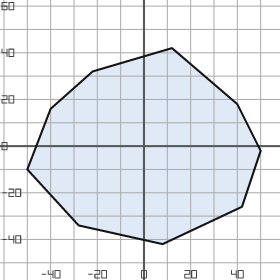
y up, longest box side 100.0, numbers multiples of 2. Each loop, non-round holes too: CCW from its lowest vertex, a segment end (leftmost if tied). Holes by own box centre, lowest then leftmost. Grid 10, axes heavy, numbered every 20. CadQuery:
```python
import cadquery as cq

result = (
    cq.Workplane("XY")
    .moveTo(8.0, -42.0)
    .lineTo(42.0, -26.0)
    .lineTo(50.0, -2.0)
    .lineTo(40.0, 18.0)
    .lineTo(12.0, 42.0)
    .lineTo(-22.0, 32.0)
    .lineTo(-40.0, 16.0)
    .lineTo(-50.0, -10.0)
    .lineTo(-28.0, -34.0)
    .close()
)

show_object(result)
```